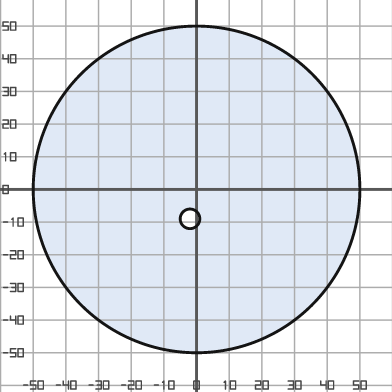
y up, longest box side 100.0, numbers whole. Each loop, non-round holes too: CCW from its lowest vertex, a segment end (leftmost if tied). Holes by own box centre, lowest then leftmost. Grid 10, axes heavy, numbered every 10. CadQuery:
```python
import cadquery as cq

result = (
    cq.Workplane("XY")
    .moveTo(0.0, 0.0)
    .circle(50.0)
    .moveTo(-2.0, -9.0)
    .circle(3.0)
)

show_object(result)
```